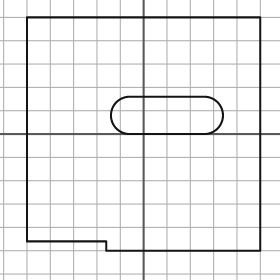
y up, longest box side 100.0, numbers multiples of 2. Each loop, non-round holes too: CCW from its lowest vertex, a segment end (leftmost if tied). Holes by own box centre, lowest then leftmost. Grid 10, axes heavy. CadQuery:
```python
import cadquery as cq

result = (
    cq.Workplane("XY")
    .moveTo(-16.0, -50.0)
    .lineTo(50.0, -50.0)
    .lineTo(50.0, 50.0)
    .lineTo(-50.0, 50.0)
    .lineTo(-50.0, -46.0)
    .lineTo(-16.0, -46.0)
    .close()
    .moveTo(-6.0, 0.0)
    .lineTo(26.0, 0.0)
    .threePointArc((34.0, 8.0), (26.0, 16.0))
    .lineTo(-6.0, 16.0)
    .threePointArc((-14.0, 8.0), (-6.0, 0.0))
    .close()
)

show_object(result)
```